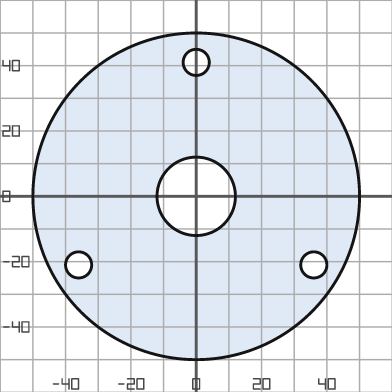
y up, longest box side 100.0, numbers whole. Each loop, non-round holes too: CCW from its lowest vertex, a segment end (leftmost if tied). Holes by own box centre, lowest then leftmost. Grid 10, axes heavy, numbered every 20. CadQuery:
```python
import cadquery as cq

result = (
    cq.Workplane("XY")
    .moveTo(0.0, 0.0)
    .circle(50.0)
    .moveTo(-36.0, -21.0)
    .circle(4.0)
    .moveTo(36.0, -21.0)
    .circle(4.0)
    .moveTo(0.0, 0.0)
    .circle(12.0)
    .moveTo(0.0, 41.0)
    .circle(4.0)
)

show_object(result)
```